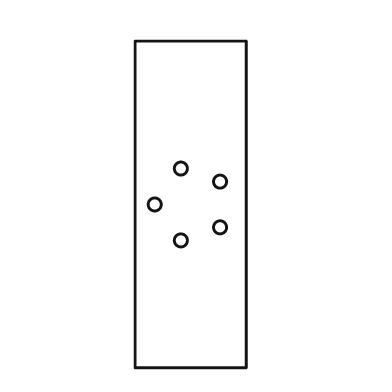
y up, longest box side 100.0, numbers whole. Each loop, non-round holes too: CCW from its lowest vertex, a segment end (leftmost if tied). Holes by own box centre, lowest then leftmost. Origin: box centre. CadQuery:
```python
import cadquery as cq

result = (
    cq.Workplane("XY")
    .moveTo(-17.0, -50.0)
    .lineTo(17.0, -50.0)
    .lineTo(17.0, 50.0)
    .lineTo(-17.0, 50.0)
    .close()
    .moveTo(-3.0, -11.0)
    .circle(2.0)
    .moveTo(9.0, -7.0)
    .circle(2.0)
    .moveTo(-11.0, 0.0)
    .circle(2.0)
    .moveTo(9.0, 7.0)
    .circle(2.0)
    .moveTo(-3.0, 11.0)
    .circle(2.0)
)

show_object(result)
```